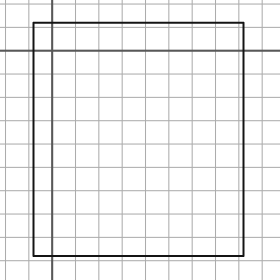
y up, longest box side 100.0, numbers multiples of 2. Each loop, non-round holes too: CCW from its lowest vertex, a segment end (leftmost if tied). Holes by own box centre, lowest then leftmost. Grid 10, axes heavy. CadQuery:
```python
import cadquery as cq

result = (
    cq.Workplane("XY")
    .moveTo(-8.0, -88.0)
    .lineTo(82.0, -88.0)
    .lineTo(82.0, 12.0)
    .lineTo(-8.0, 12.0)
    .close()
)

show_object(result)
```